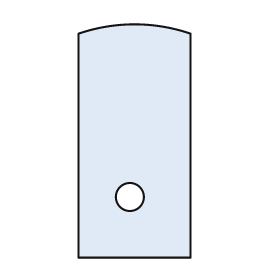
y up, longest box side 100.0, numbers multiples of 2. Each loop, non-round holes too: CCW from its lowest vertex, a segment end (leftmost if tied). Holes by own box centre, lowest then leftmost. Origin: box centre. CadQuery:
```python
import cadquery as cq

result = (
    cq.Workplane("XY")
    .moveTo(-24.0, -50.0)
    .lineTo(24.0, -50.0)
    .lineTo(24.0, 46.0)
    .threePointArc((0.0, 50.0), (-24.0, 46.0))
    .close()
    .moveTo(-2.0, -24.0)
    .circle(6.0)
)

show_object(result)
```